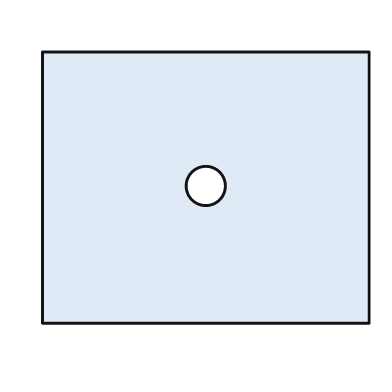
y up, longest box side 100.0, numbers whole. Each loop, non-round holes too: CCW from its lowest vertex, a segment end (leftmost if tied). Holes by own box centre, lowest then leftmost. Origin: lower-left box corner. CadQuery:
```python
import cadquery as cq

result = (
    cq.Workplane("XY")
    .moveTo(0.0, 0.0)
    .lineTo(100.0, 0.0)
    .lineTo(100.0, 83.0)
    .lineTo(0.0, 83.0)
    .close()
    .moveTo(50.0, 42.0)
    .circle(6.0)
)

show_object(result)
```